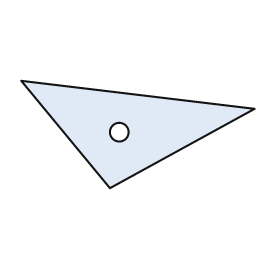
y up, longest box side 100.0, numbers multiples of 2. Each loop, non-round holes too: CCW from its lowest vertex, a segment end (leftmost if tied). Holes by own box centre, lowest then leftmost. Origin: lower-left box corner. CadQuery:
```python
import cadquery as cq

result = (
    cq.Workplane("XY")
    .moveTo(38.0, 0.0)
    .lineTo(100.0, 34.0)
    .lineTo(0.0, 46.0)
    .close()
    .moveTo(42.0, 24.0)
    .circle(4.0)
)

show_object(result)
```